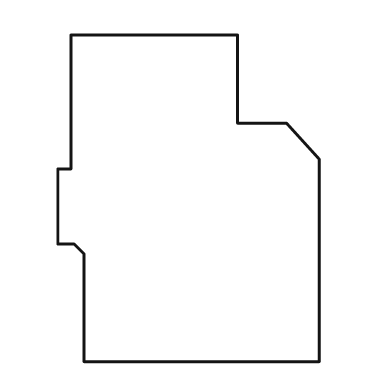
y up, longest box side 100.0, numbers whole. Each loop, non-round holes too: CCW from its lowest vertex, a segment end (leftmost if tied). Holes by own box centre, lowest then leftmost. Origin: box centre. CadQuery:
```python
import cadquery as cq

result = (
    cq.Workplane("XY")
    .moveTo(-32.0, -50.0)
    .lineTo(40.0, -50.0)
    .lineTo(40.0, 12.0)
    .lineTo(30.0, 23.0)
    .lineTo(15.0, 23.0)
    .lineTo(15.0, 50.0)
    .lineTo(-36.0, 50.0)
    .lineTo(-36.0, 9.0)
    .lineTo(-40.0, 9.0)
    .lineTo(-40.0, -14.0)
    .lineTo(-35.0, -14.0)
    .lineTo(-32.0, -17.0)
    .close()
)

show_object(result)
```